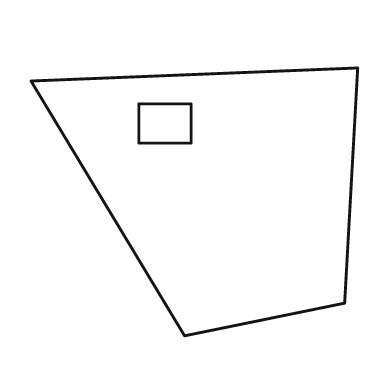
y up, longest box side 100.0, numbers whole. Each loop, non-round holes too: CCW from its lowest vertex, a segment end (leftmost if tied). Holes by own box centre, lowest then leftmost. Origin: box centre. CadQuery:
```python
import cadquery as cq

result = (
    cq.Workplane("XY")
    .moveTo(-3.0, -41.0)
    .lineTo(46.0, -31.0)
    .lineTo(50.0, 41.0)
    .lineTo(-50.0, 37.0)
    .close()
    .moveTo(-17.0, 18.0)
    .lineTo(-1.0, 18.0)
    .lineTo(-1.0, 30.0)
    .lineTo(-17.0, 30.0)
    .close()
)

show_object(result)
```